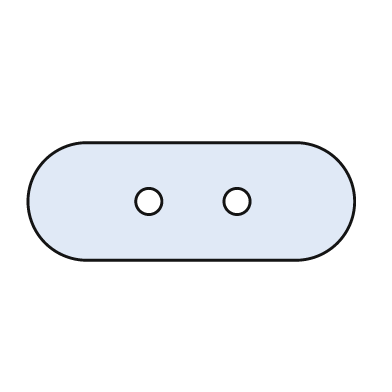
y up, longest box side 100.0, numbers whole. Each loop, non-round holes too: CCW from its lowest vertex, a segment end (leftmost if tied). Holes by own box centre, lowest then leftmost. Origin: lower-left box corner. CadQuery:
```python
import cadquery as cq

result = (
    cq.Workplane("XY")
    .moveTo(18.0, 0.0)
    .lineTo(82.0, 0.0)
    .threePointArc((100.0, 18.0), (82.0, 36.0))
    .lineTo(18.0, 36.0)
    .threePointArc((0.0, 18.0), (18.0, 0.0))
    .close()
    .moveTo(37.0, 18.0)
    .circle(4.0)
    .moveTo(64.0, 18.0)
    .circle(4.0)
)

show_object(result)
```